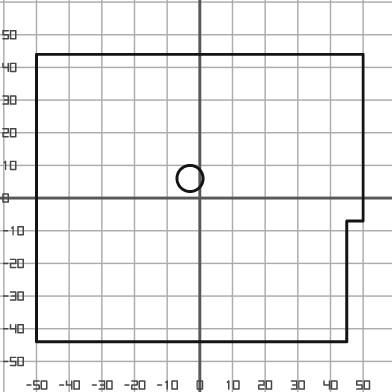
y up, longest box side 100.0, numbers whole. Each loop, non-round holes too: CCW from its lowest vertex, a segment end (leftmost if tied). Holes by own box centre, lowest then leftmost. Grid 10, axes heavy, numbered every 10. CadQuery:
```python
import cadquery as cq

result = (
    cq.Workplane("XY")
    .moveTo(-50.0, -44.0)
    .lineTo(45.0, -44.0)
    .lineTo(45.0, -7.0)
    .lineTo(50.0, -7.0)
    .lineTo(50.0, 44.0)
    .lineTo(-50.0, 44.0)
    .close()
    .moveTo(-3.0, 6.0)
    .circle(4.0)
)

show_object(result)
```